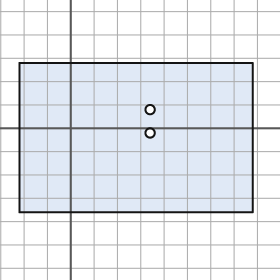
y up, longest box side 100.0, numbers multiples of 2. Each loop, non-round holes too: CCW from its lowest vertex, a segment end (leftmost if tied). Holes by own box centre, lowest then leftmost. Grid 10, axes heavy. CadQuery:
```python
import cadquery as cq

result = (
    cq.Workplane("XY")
    .moveTo(-22.0, -36.0)
    .lineTo(78.0, -36.0)
    .lineTo(78.0, 28.0)
    .lineTo(-22.0, 28.0)
    .close()
    .moveTo(34.0, -2.0)
    .circle(2.0)
    .moveTo(34.0, 8.0)
    .circle(2.0)
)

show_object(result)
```